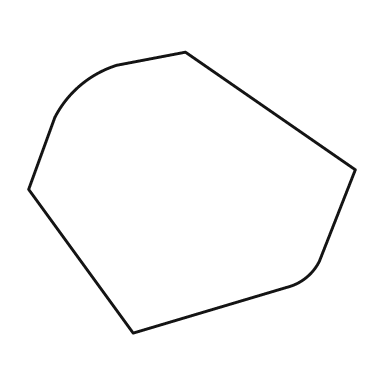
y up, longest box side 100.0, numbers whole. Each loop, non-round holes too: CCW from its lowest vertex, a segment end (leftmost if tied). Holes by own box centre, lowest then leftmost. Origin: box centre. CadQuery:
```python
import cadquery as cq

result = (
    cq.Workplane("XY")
    .moveTo(-18.0, -43.0)
    .lineTo(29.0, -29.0)
    .threePointArc((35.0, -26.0), (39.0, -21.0))
    .lineTo(50.0, 7.0)
    .lineTo(-2.0, 43.0)
    .lineTo(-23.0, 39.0)
    .threePointArc((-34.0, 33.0), (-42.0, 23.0))
    .lineTo(-50.0, 1.0)
    .close()
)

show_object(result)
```